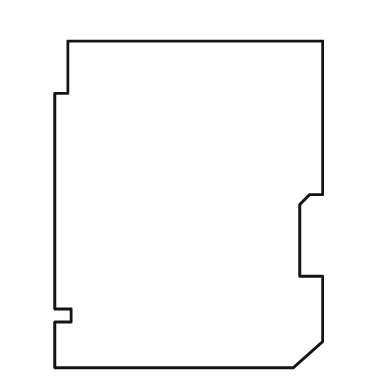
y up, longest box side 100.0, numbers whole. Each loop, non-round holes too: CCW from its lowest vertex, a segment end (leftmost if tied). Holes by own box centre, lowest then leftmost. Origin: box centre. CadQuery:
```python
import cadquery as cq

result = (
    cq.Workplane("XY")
    .moveTo(-41.0, -50.0)
    .lineTo(32.0, -50.0)
    .lineTo(41.0, -42.0)
    .lineTo(41.0, -22.0)
    .lineTo(34.0, -22.0)
    .lineTo(34.0, 0.0)
    .lineTo(37.0, 3.0)
    .lineTo(41.0, 3.0)
    .lineTo(41.0, 50.0)
    .lineTo(-37.0, 50.0)
    .lineTo(-37.0, 34.0)
    .lineTo(-41.0, 34.0)
    .lineTo(-41.0, -32.0)
    .lineTo(-36.0, -32.0)
    .lineTo(-36.0, -36.0)
    .lineTo(-41.0, -36.0)
    .close()
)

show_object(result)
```